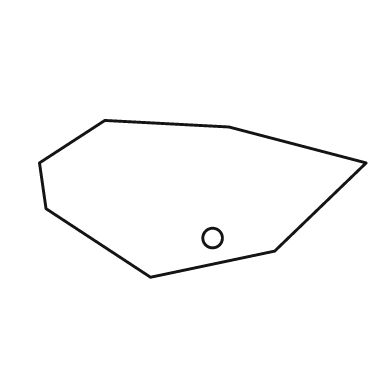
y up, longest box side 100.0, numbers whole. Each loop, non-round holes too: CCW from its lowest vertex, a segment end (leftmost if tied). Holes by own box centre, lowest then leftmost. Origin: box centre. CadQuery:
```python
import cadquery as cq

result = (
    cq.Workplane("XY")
    .moveTo(-16.0, -24.0)
    .lineTo(22.0, -16.0)
    .lineTo(50.0, 11.0)
    .lineTo(8.0, 22.0)
    .lineTo(-30.0, 24.0)
    .lineTo(-50.0, 11.0)
    .lineTo(-48.0, -3.0)
    .close()
    .moveTo(3.0, -12.0)
    .circle(3.0)
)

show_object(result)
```